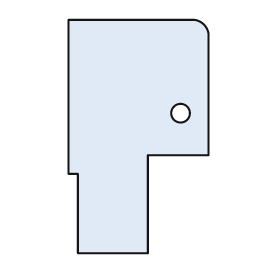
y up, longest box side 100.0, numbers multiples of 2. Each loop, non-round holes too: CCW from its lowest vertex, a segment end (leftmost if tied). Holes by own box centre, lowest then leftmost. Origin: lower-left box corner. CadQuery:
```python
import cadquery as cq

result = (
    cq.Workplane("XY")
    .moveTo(4.0, 0.0)
    .lineTo(34.0, 0.0)
    .lineTo(34.0, 42.0)
    .lineTo(60.0, 42.0)
    .lineTo(60.0, 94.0)
    .threePointArc((58.0, 98.0), (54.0, 100.0))
    .lineTo(0.0, 100.0)
    .lineTo(0.0, 34.0)
    .lineTo(4.0, 34.0)
    .close()
    .moveTo(48.0, 60.0)
    .circle(4.0)
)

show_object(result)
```